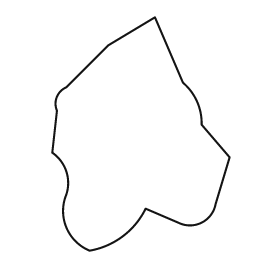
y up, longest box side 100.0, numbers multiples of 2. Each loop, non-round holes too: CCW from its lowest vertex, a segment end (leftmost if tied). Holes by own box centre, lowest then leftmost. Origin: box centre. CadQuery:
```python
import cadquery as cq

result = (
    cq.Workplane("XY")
    .moveTo(-22.0, -50.0)
    .threePointArc((-8.0, -44.0), (2.0, -32.0))
    .lineTo(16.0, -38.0)
    .threePointArc((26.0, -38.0), (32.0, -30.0))
    .lineTo(38.0, -10.0)
    .lineTo(26.0, 4.0)
    .threePointArc((24.0, 14.0), (18.0, 22.0))
    .lineTo(6.0, 50.0)
    .lineTo(-14.0, 38.0)
    .lineTo(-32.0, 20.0)
    .threePointArc((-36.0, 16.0), (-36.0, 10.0))
    .lineTo(-38.0, -8.0)
    .threePointArc((-32.0, -16.0), (-32.0, -26.0))
    .threePointArc((-32.0, -40.0), (-22.0, -50.0))
    .close()
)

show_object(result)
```